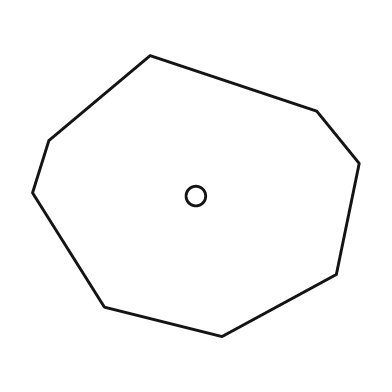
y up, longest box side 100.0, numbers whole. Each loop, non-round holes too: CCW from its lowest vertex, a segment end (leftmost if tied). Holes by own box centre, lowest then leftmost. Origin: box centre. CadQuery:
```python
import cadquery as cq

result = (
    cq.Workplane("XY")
    .moveTo(8.0, -43.0)
    .lineTo(43.0, -24.0)
    .lineTo(50.0, 10.0)
    .lineTo(37.0, 26.0)
    .lineTo(-14.0, 43.0)
    .lineTo(-45.0, 17.0)
    .lineTo(-50.0, 1.0)
    .lineTo(-28.0, -34.0)
    .close()
    .moveTo(0.0, 0.0)
    .circle(3.0)
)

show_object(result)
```